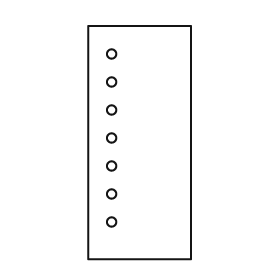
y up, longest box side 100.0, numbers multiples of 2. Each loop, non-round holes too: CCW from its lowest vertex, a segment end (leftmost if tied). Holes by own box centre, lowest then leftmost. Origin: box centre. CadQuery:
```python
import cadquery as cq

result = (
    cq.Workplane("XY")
    .moveTo(-22.0, -50.0)
    .lineTo(22.0, -50.0)
    .lineTo(22.0, 50.0)
    .lineTo(-22.0, 50.0)
    .close()
    .moveTo(-12.0, -34.0)
    .circle(2.0)
    .moveTo(-12.0, -22.0)
    .circle(2.0)
    .moveTo(-12.0, -10.0)
    .circle(2.0)
    .moveTo(-12.0, 2.0)
    .circle(2.0)
    .moveTo(-12.0, 14.0)
    .circle(2.0)
    .moveTo(-12.0, 26.0)
    .circle(2.0)
    .moveTo(-12.0, 38.0)
    .circle(2.0)
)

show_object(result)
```